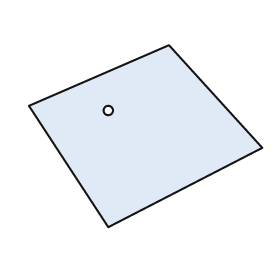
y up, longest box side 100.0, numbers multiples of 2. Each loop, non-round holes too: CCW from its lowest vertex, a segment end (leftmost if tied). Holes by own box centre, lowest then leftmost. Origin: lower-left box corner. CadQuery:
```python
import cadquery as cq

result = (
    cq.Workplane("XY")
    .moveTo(34.0, 0.0)
    .lineTo(100.0, 34.0)
    .lineTo(60.0, 78.0)
    .lineTo(0.0, 52.0)
    .close()
    .moveTo(34.0, 50.0)
    .circle(2.0)
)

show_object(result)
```